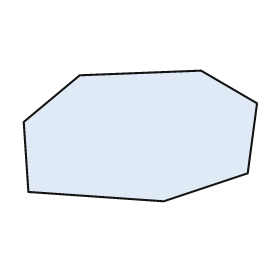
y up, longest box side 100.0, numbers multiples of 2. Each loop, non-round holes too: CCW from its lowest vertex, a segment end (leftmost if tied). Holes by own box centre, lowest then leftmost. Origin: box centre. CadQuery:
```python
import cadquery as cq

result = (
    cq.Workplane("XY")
    .moveTo(10.0, -28.0)
    .lineTo(46.0, -16.0)
    .lineTo(50.0, 14.0)
    .lineTo(26.0, 28.0)
    .lineTo(-26.0, 26.0)
    .lineTo(-50.0, 6.0)
    .lineTo(-48.0, -24.0)
    .close()
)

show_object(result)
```